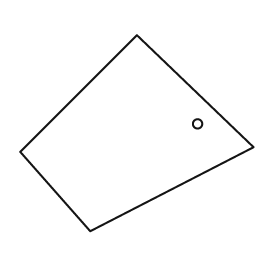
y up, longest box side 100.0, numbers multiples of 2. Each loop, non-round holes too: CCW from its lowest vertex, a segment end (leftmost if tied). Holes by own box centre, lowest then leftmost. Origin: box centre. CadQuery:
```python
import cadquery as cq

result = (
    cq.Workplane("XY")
    .moveTo(-20.0, -42.0)
    .lineTo(50.0, -6.0)
    .lineTo(0.0, 42.0)
    .lineTo(-50.0, -8.0)
    .close()
    .moveTo(26.0, 4.0)
    .circle(2.0)
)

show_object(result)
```